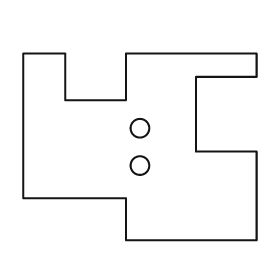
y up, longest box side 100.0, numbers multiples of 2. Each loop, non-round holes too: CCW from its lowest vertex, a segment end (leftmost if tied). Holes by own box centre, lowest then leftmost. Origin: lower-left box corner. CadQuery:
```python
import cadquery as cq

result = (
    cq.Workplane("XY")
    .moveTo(44.0, 0.0)
    .lineTo(100.0, 0.0)
    .lineTo(100.0, 38.0)
    .lineTo(74.0, 38.0)
    .lineTo(74.0, 70.0)
    .lineTo(100.0, 70.0)
    .lineTo(100.0, 80.0)
    .lineTo(44.0, 80.0)
    .lineTo(44.0, 60.0)
    .lineTo(18.0, 60.0)
    .lineTo(18.0, 80.0)
    .lineTo(0.0, 80.0)
    .lineTo(0.0, 18.0)
    .lineTo(44.0, 18.0)
    .close()
    .moveTo(50.0, 32.0)
    .circle(4.0)
    .moveTo(50.0, 48.0)
    .circle(4.0)
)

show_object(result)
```